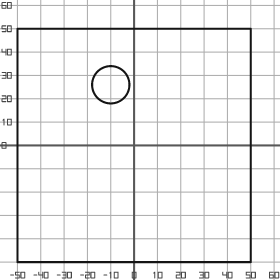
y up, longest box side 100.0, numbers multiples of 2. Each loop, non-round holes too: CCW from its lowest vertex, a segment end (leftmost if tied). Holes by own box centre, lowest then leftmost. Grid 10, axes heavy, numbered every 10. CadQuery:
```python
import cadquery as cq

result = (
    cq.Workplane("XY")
    .moveTo(-50.0, -50.0)
    .lineTo(50.0, -50.0)
    .lineTo(50.0, 50.0)
    .lineTo(-50.0, 50.0)
    .close()
    .moveTo(-10.0, 26.0)
    .circle(8.0)
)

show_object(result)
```